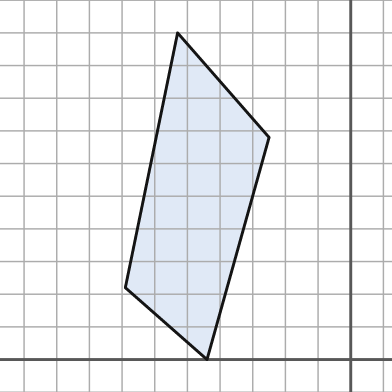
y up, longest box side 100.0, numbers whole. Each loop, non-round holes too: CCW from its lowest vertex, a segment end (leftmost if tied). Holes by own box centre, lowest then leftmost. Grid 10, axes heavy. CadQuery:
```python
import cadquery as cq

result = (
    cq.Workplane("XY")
    .moveTo(-44.0, 0.0)
    .lineTo(-25.0, 68.0)
    .lineTo(-53.0, 100.0)
    .lineTo(-69.0, 22.0)
    .close()
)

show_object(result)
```